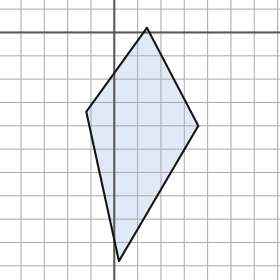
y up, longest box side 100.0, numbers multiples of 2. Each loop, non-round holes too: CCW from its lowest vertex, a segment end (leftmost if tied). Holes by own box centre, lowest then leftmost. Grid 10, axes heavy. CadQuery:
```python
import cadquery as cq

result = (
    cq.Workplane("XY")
    .moveTo(2.0, -98.0)
    .lineTo(36.0, -40.0)
    .lineTo(14.0, 2.0)
    .lineTo(-12.0, -34.0)
    .close()
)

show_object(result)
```